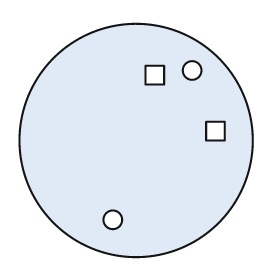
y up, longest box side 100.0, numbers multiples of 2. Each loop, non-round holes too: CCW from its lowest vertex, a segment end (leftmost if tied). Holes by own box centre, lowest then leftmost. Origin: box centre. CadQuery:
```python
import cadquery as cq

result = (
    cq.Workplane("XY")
    .moveTo(0.0, 0.0)
    .circle(50.0)
    .moveTo(-10.0, -34.0)
    .circle(4.0)
    .moveTo(30.0, 0.0)
    .lineTo(38.0, 0.0)
    .lineTo(38.0, 8.0)
    .lineTo(30.0, 8.0)
    .close()
    .moveTo(4.0, 24.0)
    .lineTo(12.0, 24.0)
    .lineTo(12.0, 32.0)
    .lineTo(4.0, 32.0)
    .close()
    .moveTo(24.0, 30.0)
    .circle(4.0)
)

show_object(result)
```